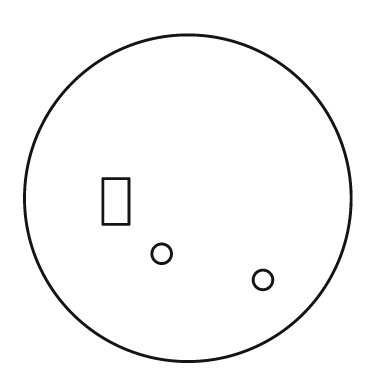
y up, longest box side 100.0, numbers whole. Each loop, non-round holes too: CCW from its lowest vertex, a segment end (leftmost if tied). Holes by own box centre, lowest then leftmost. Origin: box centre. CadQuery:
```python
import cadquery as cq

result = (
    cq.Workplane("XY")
    .moveTo(0.0, 0.0)
    .circle(50.0)
    .moveTo(23.0, -25.0)
    .circle(3.0)
    .moveTo(-8.0, -17.0)
    .circle(3.0)
    .moveTo(-26.0, -8.0)
    .lineTo(-18.0, -8.0)
    .lineTo(-18.0, 6.0)
    .lineTo(-26.0, 6.0)
    .close()
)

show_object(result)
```